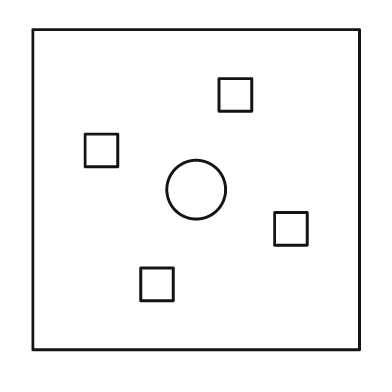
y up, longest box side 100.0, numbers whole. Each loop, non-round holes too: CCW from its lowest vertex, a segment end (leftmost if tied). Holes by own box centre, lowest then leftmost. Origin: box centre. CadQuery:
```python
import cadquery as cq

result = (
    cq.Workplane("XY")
    .moveTo(-50.0, -49.0)
    .lineTo(50.0, -49.0)
    .lineTo(50.0, 49.0)
    .lineTo(-50.0, 49.0)
    .close()
    .moveTo(-17.0, -34.0)
    .lineTo(-7.0, -34.0)
    .lineTo(-7.0, -24.0)
    .lineTo(-17.0, -24.0)
    .close()
    .moveTo(24.0, -17.0)
    .lineTo(34.0, -17.0)
    .lineTo(34.0, -7.0)
    .lineTo(24.0, -7.0)
    .close()
    .moveTo(0.0, 0.0)
    .circle(9.0)
    .moveTo(-34.0, 7.0)
    .lineTo(-24.0, 7.0)
    .lineTo(-24.0, 17.0)
    .lineTo(-34.0, 17.0)
    .close()
    .moveTo(7.0, 24.0)
    .lineTo(17.0, 24.0)
    .lineTo(17.0, 34.0)
    .lineTo(7.0, 34.0)
    .close()
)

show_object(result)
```